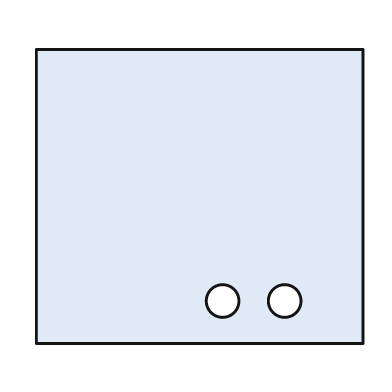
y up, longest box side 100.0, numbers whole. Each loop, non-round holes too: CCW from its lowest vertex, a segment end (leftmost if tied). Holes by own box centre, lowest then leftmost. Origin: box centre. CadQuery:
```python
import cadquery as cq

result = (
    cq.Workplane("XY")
    .moveTo(-50.0, -45.0)
    .lineTo(50.0, -45.0)
    .lineTo(50.0, 45.0)
    .lineTo(-50.0, 45.0)
    .close()
    .moveTo(7.0, -32.0)
    .circle(5.0)
    .moveTo(26.0, -32.0)
    .circle(5.0)
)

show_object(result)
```